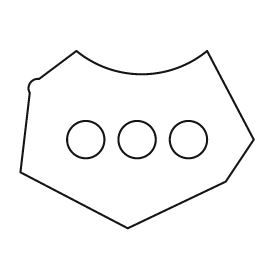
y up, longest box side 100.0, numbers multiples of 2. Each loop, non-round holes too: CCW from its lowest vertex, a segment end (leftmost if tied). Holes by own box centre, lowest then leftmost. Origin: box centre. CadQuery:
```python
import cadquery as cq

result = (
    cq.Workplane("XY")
    .moveTo(-4.0, -38.0)
    .lineTo(38.0, -18.0)
    .lineTo(50.0, 0.0)
    .lineTo(30.0, 38.0)
    .threePointArc((2.0, 28.0), (-26.0, 38.0))
    .lineTo(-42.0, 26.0)
    .threePointArc((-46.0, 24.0), (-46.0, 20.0))
    .lineTo(-50.0, -14.0)
    .close()
    .moveTo(-22.0, 0.0)
    .circle(8.0)
    .moveTo(0.0, 0.0)
    .circle(8.0)
    .moveTo(22.0, 0.0)
    .circle(8.0)
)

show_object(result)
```